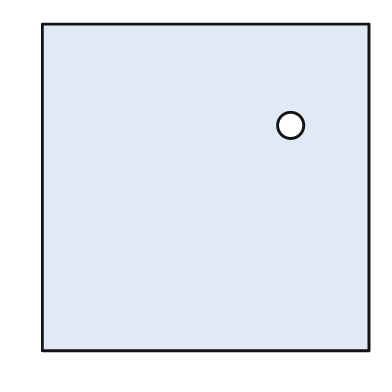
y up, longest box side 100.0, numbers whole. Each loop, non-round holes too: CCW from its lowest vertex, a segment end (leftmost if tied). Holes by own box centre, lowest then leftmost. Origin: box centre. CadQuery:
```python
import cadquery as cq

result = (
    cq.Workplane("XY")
    .moveTo(-50.0, -50.0)
    .lineTo(50.0, -50.0)
    .lineTo(50.0, 50.0)
    .lineTo(-50.0, 50.0)
    .close()
    .moveTo(26.0, 19.0)
    .circle(4.0)
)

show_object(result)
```